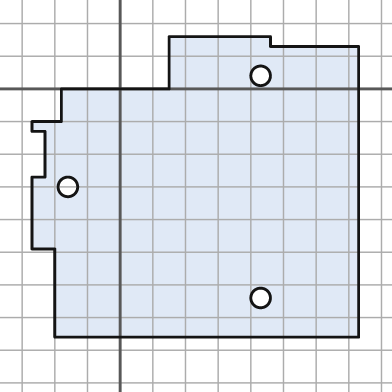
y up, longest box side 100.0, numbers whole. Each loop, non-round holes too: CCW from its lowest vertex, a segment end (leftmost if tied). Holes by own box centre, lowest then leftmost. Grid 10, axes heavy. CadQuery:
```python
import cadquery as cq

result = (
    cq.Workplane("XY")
    .moveTo(-20.0, -76.0)
    .lineTo(73.0, -76.0)
    .lineTo(73.0, 13.0)
    .lineTo(46.0, 13.0)
    .lineTo(46.0, 16.0)
    .lineTo(15.0, 16.0)
    .lineTo(15.0, 0.0)
    .lineTo(-18.0, 0.0)
    .lineTo(-18.0, -10.0)
    .lineTo(-27.0, -10.0)
    .lineTo(-27.0, -13.0)
    .lineTo(-23.0, -13.0)
    .lineTo(-23.0, -27.0)
    .lineTo(-27.0, -27.0)
    .lineTo(-27.0, -49.0)
    .lineTo(-20.0, -49.0)
    .close()
    .moveTo(43.0, -64.0)
    .circle(3.0)
    .moveTo(-16.0, -30.0)
    .circle(3.0)
    .moveTo(43.0, 4.0)
    .circle(3.0)
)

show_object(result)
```